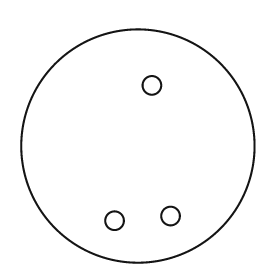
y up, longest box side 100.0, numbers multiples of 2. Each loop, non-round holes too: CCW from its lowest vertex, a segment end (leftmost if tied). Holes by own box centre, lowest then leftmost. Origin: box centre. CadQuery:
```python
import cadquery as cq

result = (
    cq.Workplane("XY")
    .moveTo(0.0, 0.0)
    .circle(50.0)
    .moveTo(-10.0, -32.0)
    .circle(4.0)
    .moveTo(14.0, -30.0)
    .circle(4.0)
    .moveTo(6.0, 26.0)
    .circle(4.0)
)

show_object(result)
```